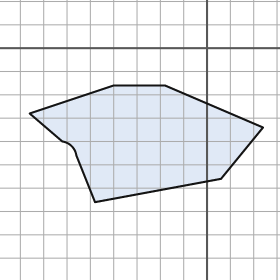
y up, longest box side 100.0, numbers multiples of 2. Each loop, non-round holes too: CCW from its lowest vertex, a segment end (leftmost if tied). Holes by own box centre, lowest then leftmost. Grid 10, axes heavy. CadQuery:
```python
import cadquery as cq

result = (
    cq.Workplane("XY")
    .moveTo(-48.0, -66.0)
    .lineTo(6.0, -56.0)
    .lineTo(24.0, -34.0)
    .lineTo(-18.0, -16.0)
    .lineTo(-40.0, -16.0)
    .lineTo(-76.0, -28.0)
    .lineTo(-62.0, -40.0)
    .threePointArc((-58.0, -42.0), (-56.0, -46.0))
    .close()
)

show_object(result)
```